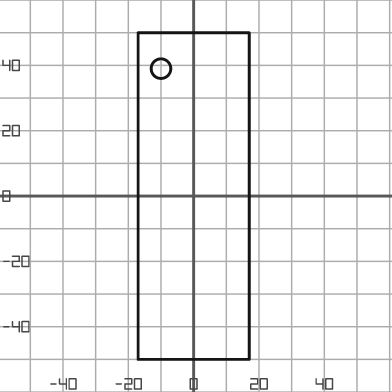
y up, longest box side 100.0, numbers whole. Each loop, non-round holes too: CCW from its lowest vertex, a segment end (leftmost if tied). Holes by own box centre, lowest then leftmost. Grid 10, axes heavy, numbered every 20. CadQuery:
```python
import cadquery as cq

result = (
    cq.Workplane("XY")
    .moveTo(-17.0, -50.0)
    .lineTo(17.0, -50.0)
    .lineTo(17.0, 50.0)
    .lineTo(-17.0, 50.0)
    .close()
    .moveTo(-10.0, 39.0)
    .circle(3.0)
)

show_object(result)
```